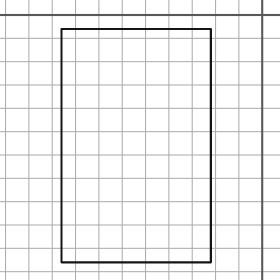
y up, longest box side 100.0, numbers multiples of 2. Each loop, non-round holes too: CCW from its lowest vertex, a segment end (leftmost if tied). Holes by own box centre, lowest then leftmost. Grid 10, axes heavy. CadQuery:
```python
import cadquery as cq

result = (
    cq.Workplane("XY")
    .moveTo(-86.0, -106.0)
    .lineTo(-22.0, -106.0)
    .lineTo(-22.0, -6.0)
    .lineTo(-86.0, -6.0)
    .close()
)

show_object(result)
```